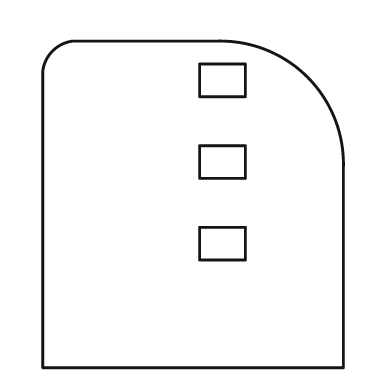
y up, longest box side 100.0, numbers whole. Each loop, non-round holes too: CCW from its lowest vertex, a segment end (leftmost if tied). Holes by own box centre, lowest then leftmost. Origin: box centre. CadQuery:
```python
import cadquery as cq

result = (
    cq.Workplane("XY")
    .moveTo(-46.0, -50.0)
    .lineTo(46.0, -50.0)
    .lineTo(46.0, 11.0)
    .threePointArc((35.0, 39.0), (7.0, 50.0))
    .lineTo(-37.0, 50.0)
    .threePointArc((-43.0, 47.0), (-46.0, 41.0))
    .close()
    .moveTo(2.0, -17.0)
    .lineTo(16.0, -17.0)
    .lineTo(16.0, -7.0)
    .lineTo(2.0, -7.0)
    .close()
    .moveTo(2.0, 8.0)
    .lineTo(16.0, 8.0)
    .lineTo(16.0, 18.0)
    .lineTo(2.0, 18.0)
    .close()
    .moveTo(2.0, 33.0)
    .lineTo(16.0, 33.0)
    .lineTo(16.0, 43.0)
    .lineTo(2.0, 43.0)
    .close()
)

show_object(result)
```